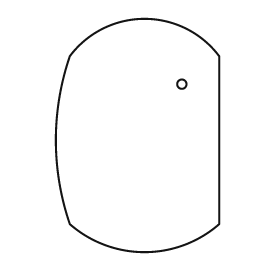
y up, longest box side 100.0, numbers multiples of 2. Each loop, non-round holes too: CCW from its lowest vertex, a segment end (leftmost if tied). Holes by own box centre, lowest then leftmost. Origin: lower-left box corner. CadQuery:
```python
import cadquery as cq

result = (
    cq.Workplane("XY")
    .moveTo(6.0, 12.0)
    .threePointArc((38.0, 0.0), (70.0, 12.0))
    .lineTo(70.0, 84.0)
    .threePointArc((38.0, 100.0), (6.0, 84.0))
    .threePointArc((0.0, 48.0), (6.0, 12.0))
    .close()
    .moveTo(54.0, 72.0)
    .circle(2.0)
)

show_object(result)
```